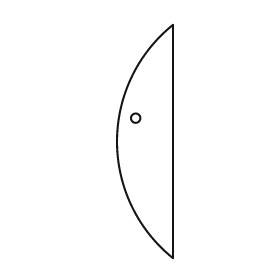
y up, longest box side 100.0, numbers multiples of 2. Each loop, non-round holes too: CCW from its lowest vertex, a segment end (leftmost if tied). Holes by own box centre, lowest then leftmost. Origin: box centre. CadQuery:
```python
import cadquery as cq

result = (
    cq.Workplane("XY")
    .moveTo(12.0, -50.0)
    .lineTo(12.0, 50.0)
    .threePointArc((-12.0, 0.0), (12.0, -50.0))
    .close()
    .moveTo(-4.0, 10.0)
    .circle(2.0)
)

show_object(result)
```